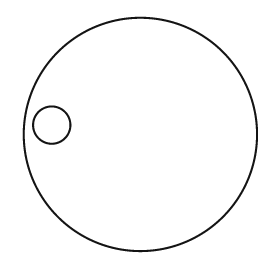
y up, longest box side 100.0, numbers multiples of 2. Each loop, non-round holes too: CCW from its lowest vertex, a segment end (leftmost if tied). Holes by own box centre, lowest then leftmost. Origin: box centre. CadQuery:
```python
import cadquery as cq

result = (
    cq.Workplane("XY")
    .moveTo(0.0, 0.0)
    .circle(50.0)
    .moveTo(-38.0, 4.0)
    .circle(8.0)
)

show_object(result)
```